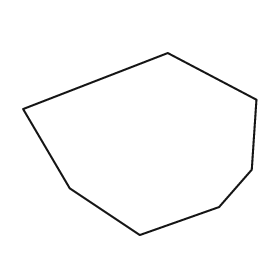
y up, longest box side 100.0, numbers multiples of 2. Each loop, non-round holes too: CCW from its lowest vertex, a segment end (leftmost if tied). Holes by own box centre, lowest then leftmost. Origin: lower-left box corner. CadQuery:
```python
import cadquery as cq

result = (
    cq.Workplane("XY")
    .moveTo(50.0, 0.0)
    .lineTo(84.0, 12.0)
    .lineTo(98.0, 28.0)
    .lineTo(100.0, 58.0)
    .lineTo(62.0, 78.0)
    .lineTo(0.0, 54.0)
    .lineTo(20.0, 20.0)
    .close()
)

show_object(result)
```